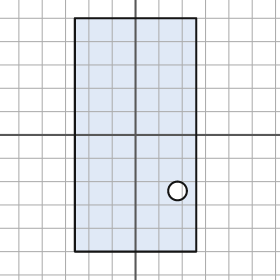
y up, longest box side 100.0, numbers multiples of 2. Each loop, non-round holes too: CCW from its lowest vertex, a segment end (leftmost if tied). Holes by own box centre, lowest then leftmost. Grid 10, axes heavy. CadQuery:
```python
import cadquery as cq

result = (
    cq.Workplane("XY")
    .moveTo(-26.0, -50.0)
    .lineTo(26.0, -50.0)
    .lineTo(26.0, 50.0)
    .lineTo(-26.0, 50.0)
    .close()
    .moveTo(18.0, -24.0)
    .circle(4.0)
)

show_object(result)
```